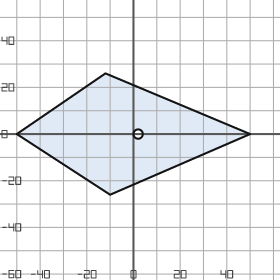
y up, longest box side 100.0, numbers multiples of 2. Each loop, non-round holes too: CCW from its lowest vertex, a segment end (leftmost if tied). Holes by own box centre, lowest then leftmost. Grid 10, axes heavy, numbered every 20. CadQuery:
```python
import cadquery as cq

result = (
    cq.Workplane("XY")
    .moveTo(-10.0, -26.0)
    .lineTo(50.0, 0.0)
    .lineTo(-12.0, 26.0)
    .lineTo(-50.0, 0.0)
    .close()
    .moveTo(2.0, 0.0)
    .circle(2.0)
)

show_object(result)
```